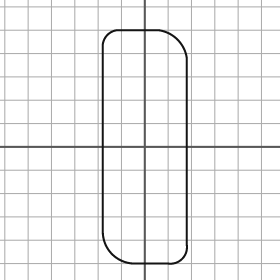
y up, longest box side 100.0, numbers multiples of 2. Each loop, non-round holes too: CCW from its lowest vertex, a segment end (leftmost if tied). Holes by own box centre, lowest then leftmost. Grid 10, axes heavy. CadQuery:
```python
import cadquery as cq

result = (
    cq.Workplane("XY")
    .moveTo(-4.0, -50.0)
    .lineTo(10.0, -50.0)
    .threePointArc((16.0, -48.0), (18.0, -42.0))
    .lineTo(18.0, 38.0)
    .threePointArc((14.0, 46.0), (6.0, 50.0))
    .lineTo(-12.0, 50.0)
    .threePointArc((-16.0, 48.0), (-18.0, 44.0))
    .lineTo(-18.0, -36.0)
    .threePointArc((-14.0, -46.0), (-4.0, -50.0))
    .close()
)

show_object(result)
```